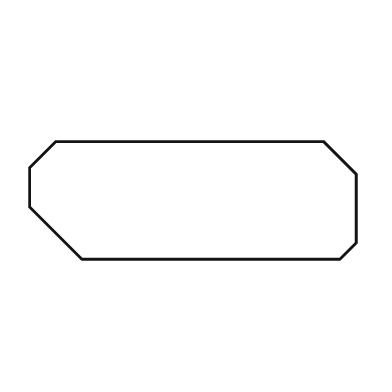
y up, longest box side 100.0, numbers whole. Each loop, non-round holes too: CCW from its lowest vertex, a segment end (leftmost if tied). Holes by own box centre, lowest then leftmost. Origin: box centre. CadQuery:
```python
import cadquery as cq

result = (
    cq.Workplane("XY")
    .moveTo(-34.0, -18.0)
    .lineTo(45.0, -18.0)
    .lineTo(50.0, -13.0)
    .lineTo(50.0, 8.0)
    .lineTo(40.0, 18.0)
    .lineTo(-42.0, 18.0)
    .lineTo(-50.0, 10.0)
    .lineTo(-50.0, -2.0)
    .close()
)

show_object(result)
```